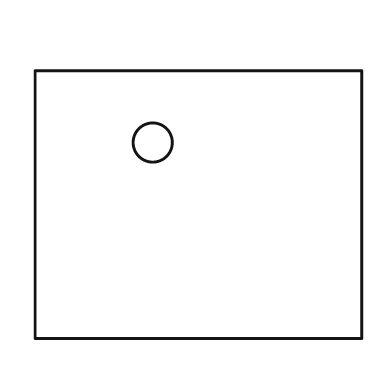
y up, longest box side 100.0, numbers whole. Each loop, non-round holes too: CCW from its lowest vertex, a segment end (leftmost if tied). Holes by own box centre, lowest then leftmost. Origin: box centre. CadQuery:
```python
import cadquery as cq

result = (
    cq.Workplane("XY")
    .moveTo(-50.0, -41.0)
    .lineTo(50.0, -41.0)
    .lineTo(50.0, 41.0)
    .lineTo(-50.0, 41.0)
    .close()
    .moveTo(-14.0, 19.0)
    .circle(6.0)
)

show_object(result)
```